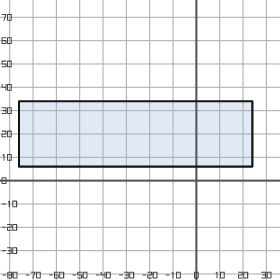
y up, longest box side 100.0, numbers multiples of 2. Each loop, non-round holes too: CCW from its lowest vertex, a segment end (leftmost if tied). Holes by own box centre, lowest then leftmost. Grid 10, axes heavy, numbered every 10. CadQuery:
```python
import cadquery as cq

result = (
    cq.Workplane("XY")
    .moveTo(-76.0, 6.0)
    .lineTo(24.0, 6.0)
    .lineTo(24.0, 34.0)
    .lineTo(-76.0, 34.0)
    .close()
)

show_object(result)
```